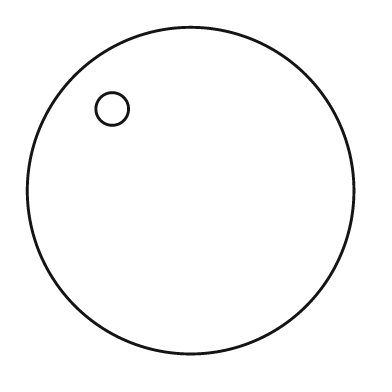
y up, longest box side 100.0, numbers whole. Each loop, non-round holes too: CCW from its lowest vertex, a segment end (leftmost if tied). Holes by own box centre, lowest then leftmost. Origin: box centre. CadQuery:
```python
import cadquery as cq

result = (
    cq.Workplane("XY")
    .moveTo(0.0, 0.0)
    .circle(50.0)
    .moveTo(-24.0, 25.0)
    .circle(5.0)
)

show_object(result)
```